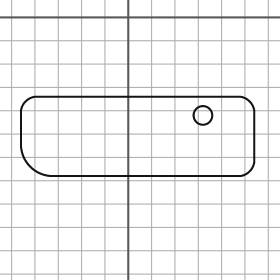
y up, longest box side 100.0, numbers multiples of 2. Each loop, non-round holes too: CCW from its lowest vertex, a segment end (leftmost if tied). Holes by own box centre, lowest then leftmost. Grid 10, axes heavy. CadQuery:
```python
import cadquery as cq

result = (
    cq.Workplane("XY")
    .moveTo(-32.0, -68.0)
    .lineTo(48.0, -68.0)
    .threePointArc((52.0, -66.0), (54.0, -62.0))
    .lineTo(54.0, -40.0)
    .threePointArc((52.0, -36.0), (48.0, -34.0))
    .lineTo(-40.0, -34.0)
    .threePointArc((-44.0, -36.0), (-46.0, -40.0))
    .lineTo(-46.0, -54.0)
    .threePointArc((-42.0, -64.0), (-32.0, -68.0))
    .close()
    .moveTo(32.0, -42.0)
    .circle(4.0)
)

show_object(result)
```